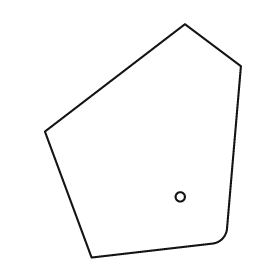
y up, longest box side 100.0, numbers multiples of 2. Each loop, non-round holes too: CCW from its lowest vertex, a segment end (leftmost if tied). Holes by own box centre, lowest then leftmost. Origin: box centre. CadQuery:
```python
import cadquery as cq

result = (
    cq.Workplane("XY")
    .moveTo(-22.0, -50.0)
    .lineTo(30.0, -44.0)
    .threePointArc((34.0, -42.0), (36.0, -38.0))
    .lineTo(42.0, 32.0)
    .lineTo(18.0, 50.0)
    .lineTo(-42.0, 4.0)
    .close()
    .moveTo(16.0, -24.0)
    .circle(2.0)
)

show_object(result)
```